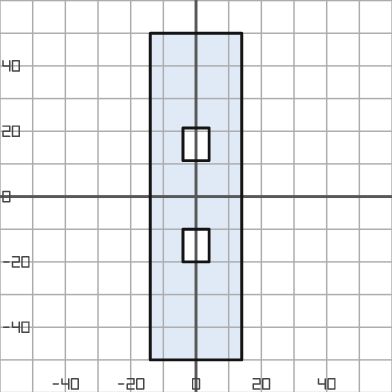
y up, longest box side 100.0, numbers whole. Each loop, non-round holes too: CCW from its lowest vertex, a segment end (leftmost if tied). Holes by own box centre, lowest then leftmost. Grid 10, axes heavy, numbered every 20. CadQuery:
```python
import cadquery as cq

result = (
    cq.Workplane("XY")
    .moveTo(-14.0, -50.0)
    .lineTo(14.0, -50.0)
    .lineTo(14.0, 50.0)
    .lineTo(-14.0, 50.0)
    .close()
    .moveTo(-4.0, -20.0)
    .lineTo(4.0, -20.0)
    .lineTo(4.0, -10.0)
    .lineTo(-4.0, -10.0)
    .close()
    .moveTo(-4.0, 11.0)
    .lineTo(4.0, 11.0)
    .lineTo(4.0, 21.0)
    .lineTo(-4.0, 21.0)
    .close()
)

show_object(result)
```